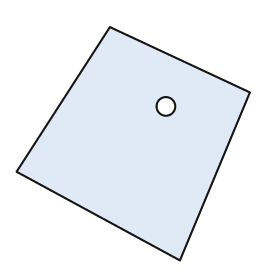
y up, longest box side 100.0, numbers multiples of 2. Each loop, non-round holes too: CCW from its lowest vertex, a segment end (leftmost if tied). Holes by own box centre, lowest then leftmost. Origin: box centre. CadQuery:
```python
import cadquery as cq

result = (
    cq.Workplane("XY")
    .moveTo(20.0, -50.0)
    .lineTo(50.0, 22.0)
    .lineTo(-10.0, 50.0)
    .lineTo(-50.0, -12.0)
    .close()
    .moveTo(14.0, 16.0)
    .circle(4.0)
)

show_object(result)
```